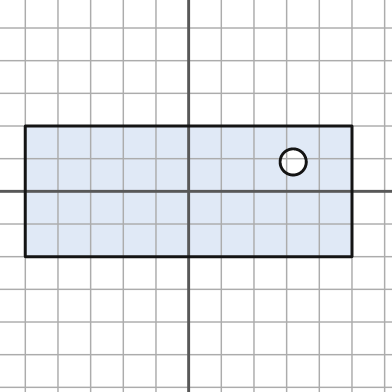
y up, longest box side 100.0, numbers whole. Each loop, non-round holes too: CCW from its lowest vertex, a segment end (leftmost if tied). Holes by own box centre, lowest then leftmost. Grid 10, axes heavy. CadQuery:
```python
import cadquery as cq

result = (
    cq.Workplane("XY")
    .moveTo(-50.0, -20.0)
    .lineTo(50.0, -20.0)
    .lineTo(50.0, 20.0)
    .lineTo(-50.0, 20.0)
    .close()
    .moveTo(32.0, 9.0)
    .circle(4.0)
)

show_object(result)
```